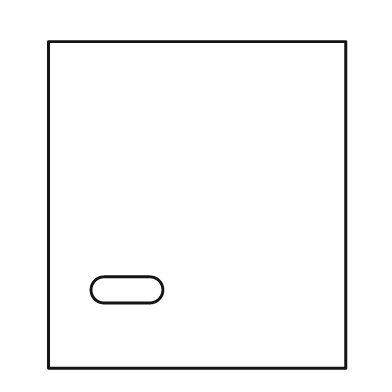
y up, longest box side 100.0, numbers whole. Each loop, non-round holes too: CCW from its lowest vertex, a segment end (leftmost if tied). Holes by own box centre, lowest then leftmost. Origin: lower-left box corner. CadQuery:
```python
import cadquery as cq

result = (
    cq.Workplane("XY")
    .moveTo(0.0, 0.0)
    .lineTo(91.0, 0.0)
    .lineTo(91.0, 100.0)
    .lineTo(0.0, 100.0)
    .close()
    .moveTo(17.0, 20.0)
    .lineTo(31.0, 20.0)
    .threePointArc((35.0, 24.0), (31.0, 28.0))
    .lineTo(17.0, 28.0)
    .threePointArc((13.0, 24.0), (17.0, 20.0))
    .close()
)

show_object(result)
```